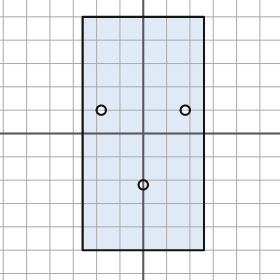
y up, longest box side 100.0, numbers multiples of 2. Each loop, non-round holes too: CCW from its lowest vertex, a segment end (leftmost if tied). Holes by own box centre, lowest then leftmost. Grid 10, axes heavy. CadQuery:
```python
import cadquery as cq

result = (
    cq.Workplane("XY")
    .moveTo(-26.0, -50.0)
    .lineTo(26.0, -50.0)
    .lineTo(26.0, 50.0)
    .lineTo(-26.0, 50.0)
    .close()
    .moveTo(0.0, -22.0)
    .circle(2.0)
    .moveTo(-18.0, 10.0)
    .circle(2.0)
    .moveTo(18.0, 10.0)
    .circle(2.0)
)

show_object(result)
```